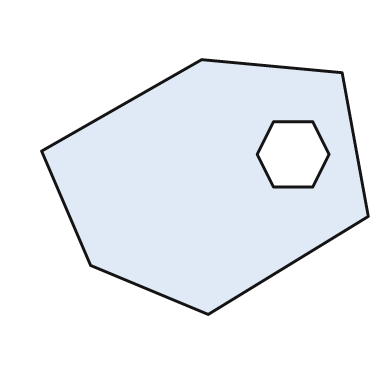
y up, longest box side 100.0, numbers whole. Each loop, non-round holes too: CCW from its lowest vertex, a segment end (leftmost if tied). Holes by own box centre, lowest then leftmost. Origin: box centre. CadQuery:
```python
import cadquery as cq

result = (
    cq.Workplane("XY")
    .moveTo(1.0, -39.0)
    .lineTo(50.0, -9.0)
    .lineTo(42.0, 35.0)
    .lineTo(-1.0, 39.0)
    .lineTo(-50.0, 11.0)
    .lineTo(-35.0, -24.0)
    .close()
    .moveTo(21.0, 0.0)
    .lineTo(33.0, 0.0)
    .lineTo(38.0, 10.0)
    .lineTo(33.0, 20.0)
    .lineTo(21.0, 20.0)
    .lineTo(16.0, 10.0)
    .close()
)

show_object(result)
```